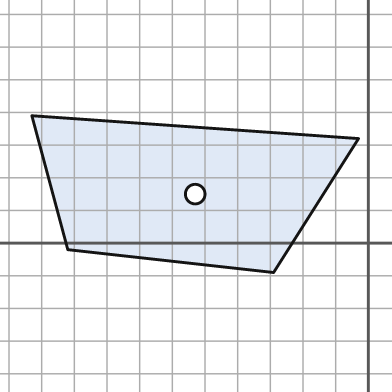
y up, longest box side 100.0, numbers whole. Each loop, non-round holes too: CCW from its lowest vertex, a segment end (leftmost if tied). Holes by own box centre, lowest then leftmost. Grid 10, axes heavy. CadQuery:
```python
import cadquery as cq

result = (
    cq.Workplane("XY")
    .moveTo(-29.0, -9.0)
    .lineTo(-3.0, 32.0)
    .lineTo(-103.0, 39.0)
    .lineTo(-92.0, -2.0)
    .close()
    .moveTo(-53.0, 15.0)
    .circle(3.0)
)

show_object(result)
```